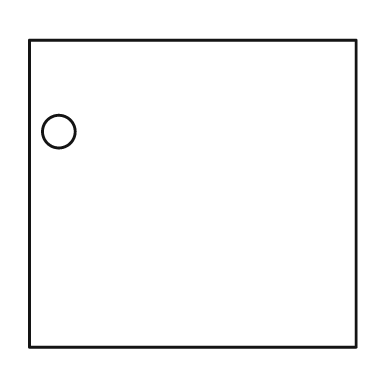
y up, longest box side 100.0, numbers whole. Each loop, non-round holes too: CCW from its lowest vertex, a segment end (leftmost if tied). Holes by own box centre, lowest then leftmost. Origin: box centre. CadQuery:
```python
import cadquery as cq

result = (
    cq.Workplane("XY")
    .moveTo(-50.0, -47.0)
    .lineTo(50.0, -47.0)
    .lineTo(50.0, 47.0)
    .lineTo(-50.0, 47.0)
    .close()
    .moveTo(-41.0, 19.0)
    .circle(5.0)
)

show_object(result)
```